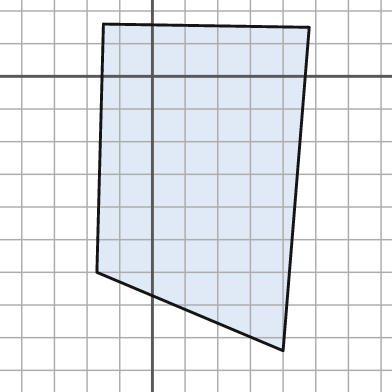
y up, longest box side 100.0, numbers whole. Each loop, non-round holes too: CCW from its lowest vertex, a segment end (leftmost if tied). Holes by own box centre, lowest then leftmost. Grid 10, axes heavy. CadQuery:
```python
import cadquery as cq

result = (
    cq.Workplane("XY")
    .moveTo(40.0, -84.0)
    .lineTo(48.0, 15.0)
    .lineTo(-15.0, 16.0)
    .lineTo(-17.0, -60.0)
    .close()
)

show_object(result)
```